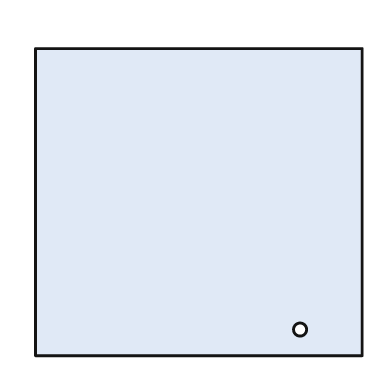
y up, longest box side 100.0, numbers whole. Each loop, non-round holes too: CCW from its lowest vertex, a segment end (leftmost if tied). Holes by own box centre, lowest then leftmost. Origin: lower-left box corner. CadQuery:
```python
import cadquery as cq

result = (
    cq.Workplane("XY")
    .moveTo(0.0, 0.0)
    .lineTo(100.0, 0.0)
    .lineTo(100.0, 94.0)
    .lineTo(0.0, 94.0)
    .close()
    .moveTo(81.0, 8.0)
    .circle(2.0)
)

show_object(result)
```